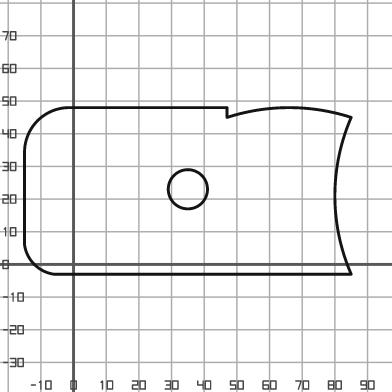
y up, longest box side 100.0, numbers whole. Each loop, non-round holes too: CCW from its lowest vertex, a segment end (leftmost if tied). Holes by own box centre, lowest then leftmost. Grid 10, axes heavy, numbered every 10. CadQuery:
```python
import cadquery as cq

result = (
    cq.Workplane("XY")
    .moveTo(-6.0, -3.0)
    .lineTo(85.0, -3.0)
    .threePointArc((80.0, 21.0), (85.0, 45.0))
    .threePointArc((66.0, 48.0), (47.0, 45.0))
    .lineTo(47.0, 48.0)
    .lineTo(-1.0, 48.0)
    .threePointArc((-11.0, 44.0), (-15.0, 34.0))
    .lineTo(-15.0, 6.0)
    .threePointArc((-12.0, 0.0), (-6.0, -3.0))
    .close()
    .moveTo(35.0, 23.0)
    .circle(6.0)
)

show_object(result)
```